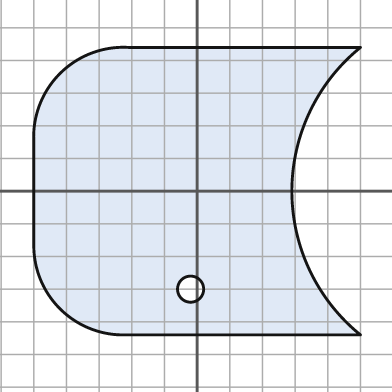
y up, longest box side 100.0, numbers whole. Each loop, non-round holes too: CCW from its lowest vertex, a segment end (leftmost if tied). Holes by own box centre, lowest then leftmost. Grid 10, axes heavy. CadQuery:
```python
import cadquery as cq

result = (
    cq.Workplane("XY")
    .moveTo(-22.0, -44.0)
    .lineTo(50.0, -44.0)
    .threePointArc((29.0, 0.0), (50.0, 44.0))
    .lineTo(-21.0, 44.0)
    .threePointArc((-42.0, 36.0), (-50.0, 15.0))
    .lineTo(-50.0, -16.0)
    .threePointArc((-42.0, -36.0), (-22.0, -44.0))
    .close()
    .moveTo(-2.0, -30.0)
    .circle(4.0)
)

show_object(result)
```